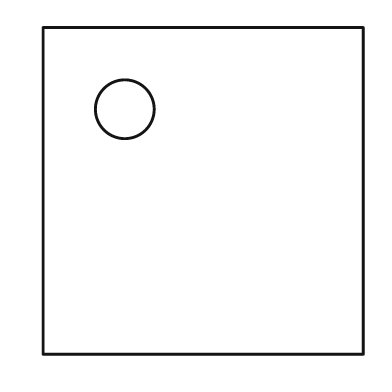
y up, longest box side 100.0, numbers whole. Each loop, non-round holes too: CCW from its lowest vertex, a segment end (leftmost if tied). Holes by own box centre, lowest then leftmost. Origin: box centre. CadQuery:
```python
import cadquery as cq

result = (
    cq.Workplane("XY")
    .moveTo(-49.0, -50.0)
    .lineTo(49.0, -50.0)
    .lineTo(49.0, 50.0)
    .lineTo(-49.0, 50.0)
    .close()
    .moveTo(-24.0, 25.0)
    .circle(9.0)
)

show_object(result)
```